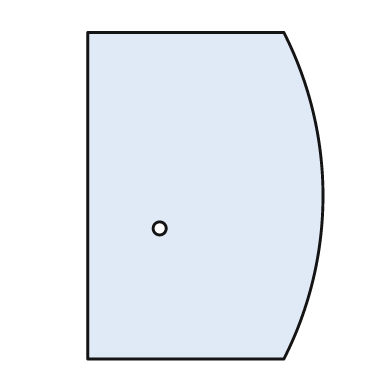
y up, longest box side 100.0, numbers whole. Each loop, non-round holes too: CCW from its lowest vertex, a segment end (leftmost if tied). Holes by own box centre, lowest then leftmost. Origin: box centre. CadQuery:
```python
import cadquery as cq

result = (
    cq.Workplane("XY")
    .moveTo(-36.0, -50.0)
    .lineTo(24.0, -50.0)
    .threePointArc((36.0, 0.0), (24.0, 50.0))
    .lineTo(-36.0, 50.0)
    .close()
    .moveTo(-14.0, -10.0)
    .circle(2.0)
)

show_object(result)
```